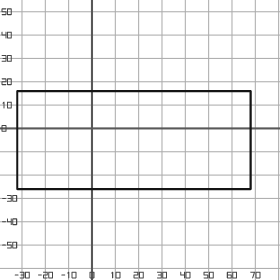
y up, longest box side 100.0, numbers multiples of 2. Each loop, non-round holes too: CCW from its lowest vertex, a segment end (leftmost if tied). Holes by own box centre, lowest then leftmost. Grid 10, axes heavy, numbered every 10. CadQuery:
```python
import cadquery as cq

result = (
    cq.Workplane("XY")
    .moveTo(-32.0, -26.0)
    .lineTo(68.0, -26.0)
    .lineTo(68.0, 16.0)
    .lineTo(-32.0, 16.0)
    .close()
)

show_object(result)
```